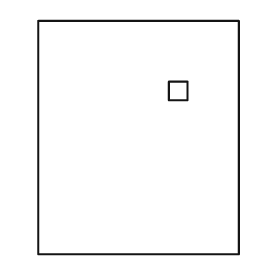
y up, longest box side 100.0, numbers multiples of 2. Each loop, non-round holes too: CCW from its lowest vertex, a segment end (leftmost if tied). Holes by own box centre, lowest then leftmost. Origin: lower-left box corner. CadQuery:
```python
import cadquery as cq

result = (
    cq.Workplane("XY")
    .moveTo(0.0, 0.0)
    .lineTo(86.0, 0.0)
    .lineTo(86.0, 100.0)
    .lineTo(0.0, 100.0)
    .close()
    .moveTo(56.0, 66.0)
    .lineTo(64.0, 66.0)
    .lineTo(64.0, 74.0)
    .lineTo(56.0, 74.0)
    .close()
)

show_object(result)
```